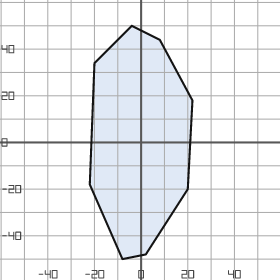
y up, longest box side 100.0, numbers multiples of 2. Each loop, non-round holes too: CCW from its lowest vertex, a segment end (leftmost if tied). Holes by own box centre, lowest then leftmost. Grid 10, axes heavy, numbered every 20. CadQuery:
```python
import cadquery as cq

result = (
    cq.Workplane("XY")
    .moveTo(-8.0, -50.0)
    .lineTo(2.0, -48.0)
    .lineTo(20.0, -20.0)
    .lineTo(22.0, 18.0)
    .lineTo(8.0, 44.0)
    .lineTo(-4.0, 50.0)
    .lineTo(-20.0, 34.0)
    .lineTo(-22.0, -18.0)
    .close()
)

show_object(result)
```